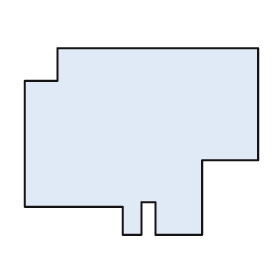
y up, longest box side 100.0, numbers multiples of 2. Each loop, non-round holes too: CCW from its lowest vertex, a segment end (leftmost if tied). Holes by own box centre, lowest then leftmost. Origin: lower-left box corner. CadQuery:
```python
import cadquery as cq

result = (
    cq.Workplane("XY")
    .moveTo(42.0, 0.0)
    .lineTo(50.0, 0.0)
    .lineTo(50.0, 14.0)
    .lineTo(56.0, 14.0)
    .lineTo(56.0, 0.0)
    .lineTo(76.0, 0.0)
    .lineTo(76.0, 32.0)
    .lineTo(100.0, 32.0)
    .lineTo(100.0, 80.0)
    .lineTo(14.0, 80.0)
    .lineTo(14.0, 66.0)
    .lineTo(0.0, 66.0)
    .lineTo(0.0, 12.0)
    .lineTo(42.0, 12.0)
    .close()
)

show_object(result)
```